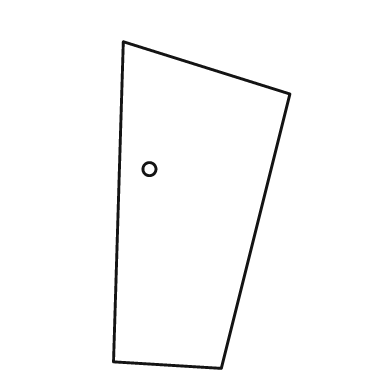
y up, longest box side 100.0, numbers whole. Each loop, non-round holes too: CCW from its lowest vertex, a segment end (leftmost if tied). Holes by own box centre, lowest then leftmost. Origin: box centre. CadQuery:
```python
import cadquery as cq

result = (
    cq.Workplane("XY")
    .moveTo(6.0, -50.0)
    .lineTo(27.0, 34.0)
    .lineTo(-24.0, 50.0)
    .lineTo(-27.0, -48.0)
    .close()
    .moveTo(-16.0, 11.0)
    .circle(2.0)
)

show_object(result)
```